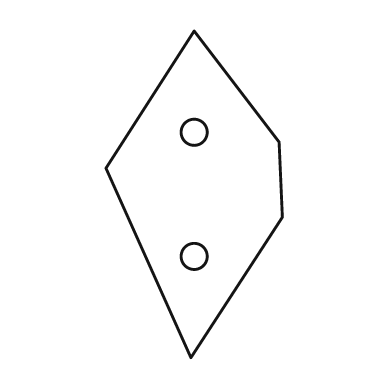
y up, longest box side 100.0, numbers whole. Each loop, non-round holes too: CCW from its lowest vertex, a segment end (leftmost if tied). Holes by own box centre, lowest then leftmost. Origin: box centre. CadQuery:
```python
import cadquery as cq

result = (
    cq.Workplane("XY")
    .moveTo(-1.0, -50.0)
    .lineTo(27.0, -7.0)
    .lineTo(26.0, 16.0)
    .lineTo(0.0, 50.0)
    .lineTo(-27.0, 8.0)
    .close()
    .moveTo(0.0, -19.0)
    .circle(4.0)
    .moveTo(0.0, 19.0)
    .circle(4.0)
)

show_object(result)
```